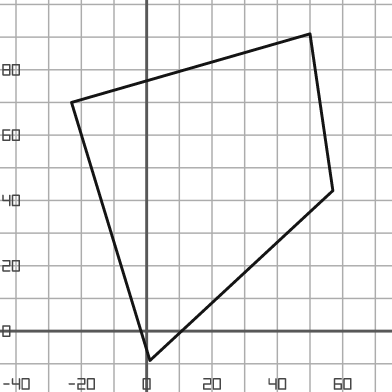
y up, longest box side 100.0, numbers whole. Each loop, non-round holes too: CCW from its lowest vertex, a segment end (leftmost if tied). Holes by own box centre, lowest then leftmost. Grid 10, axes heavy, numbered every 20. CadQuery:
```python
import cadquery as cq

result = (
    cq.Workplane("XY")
    .moveTo(1.0, -9.0)
    .lineTo(57.0, 43.0)
    .lineTo(50.0, 91.0)
    .lineTo(-23.0, 70.0)
    .close()
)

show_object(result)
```